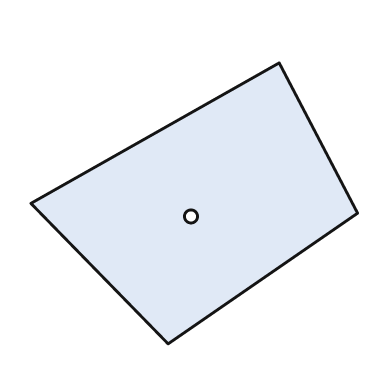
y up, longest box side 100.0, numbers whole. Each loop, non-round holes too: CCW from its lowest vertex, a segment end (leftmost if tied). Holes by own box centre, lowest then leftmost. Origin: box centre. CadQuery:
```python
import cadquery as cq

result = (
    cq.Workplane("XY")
    .moveTo(-8.0, -43.0)
    .lineTo(50.0, -3.0)
    .lineTo(26.0, 43.0)
    .lineTo(-50.0, 0.0)
    .close()
    .moveTo(-1.0, -4.0)
    .circle(2.0)
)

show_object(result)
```